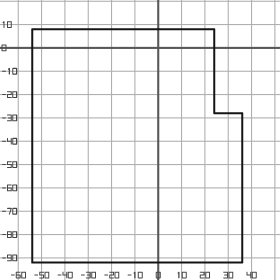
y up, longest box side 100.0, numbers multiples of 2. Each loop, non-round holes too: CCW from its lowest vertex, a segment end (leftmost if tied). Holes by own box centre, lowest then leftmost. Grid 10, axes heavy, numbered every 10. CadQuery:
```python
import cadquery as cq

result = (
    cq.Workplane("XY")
    .moveTo(-54.0, -92.0)
    .lineTo(36.0, -92.0)
    .lineTo(36.0, -28.0)
    .lineTo(24.0, -28.0)
    .lineTo(24.0, 8.0)
    .lineTo(-54.0, 8.0)
    .close()
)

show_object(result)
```